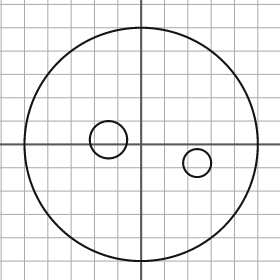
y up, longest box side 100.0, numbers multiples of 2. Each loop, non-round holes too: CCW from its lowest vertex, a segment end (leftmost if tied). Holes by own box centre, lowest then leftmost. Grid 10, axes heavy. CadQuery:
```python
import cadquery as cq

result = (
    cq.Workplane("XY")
    .moveTo(0.0, 0.0)
    .circle(50.0)
    .moveTo(24.0, -8.0)
    .circle(6.0)
    .moveTo(-14.0, 2.0)
    .circle(8.0)
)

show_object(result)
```